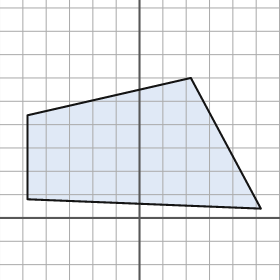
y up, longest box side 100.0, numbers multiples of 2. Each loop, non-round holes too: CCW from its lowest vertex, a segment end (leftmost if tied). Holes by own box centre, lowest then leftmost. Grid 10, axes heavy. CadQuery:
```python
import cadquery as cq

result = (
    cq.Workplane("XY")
    .moveTo(52.0, 4.0)
    .lineTo(22.0, 60.0)
    .lineTo(-48.0, 44.0)
    .lineTo(-48.0, 8.0)
    .close()
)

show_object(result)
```